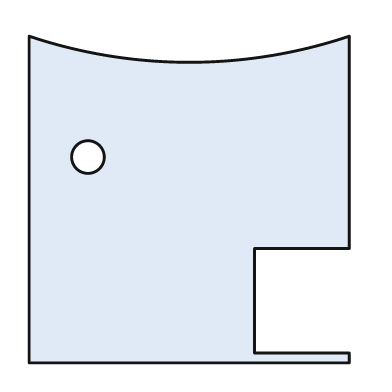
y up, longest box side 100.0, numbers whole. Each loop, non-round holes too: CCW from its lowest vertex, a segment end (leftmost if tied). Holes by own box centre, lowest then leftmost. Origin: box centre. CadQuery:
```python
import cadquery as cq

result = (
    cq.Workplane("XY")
    .moveTo(-49.0, -50.0)
    .lineTo(49.0, -50.0)
    .lineTo(49.0, -47.0)
    .lineTo(20.0, -47.0)
    .lineTo(20.0, -15.0)
    .lineTo(49.0, -15.0)
    .lineTo(49.0, 50.0)
    .threePointArc((0.0, 42.0), (-49.0, 50.0))
    .close()
    .moveTo(-31.0, 13.0)
    .circle(5.0)
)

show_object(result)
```